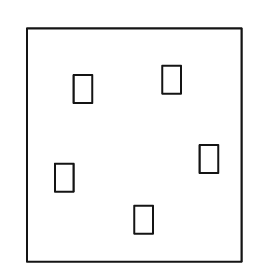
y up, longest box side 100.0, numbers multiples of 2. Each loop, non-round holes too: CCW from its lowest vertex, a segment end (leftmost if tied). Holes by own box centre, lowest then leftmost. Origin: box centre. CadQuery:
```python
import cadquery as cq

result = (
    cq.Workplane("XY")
    .moveTo(-46.0, -50.0)
    .lineTo(46.0, -50.0)
    .lineTo(46.0, 50.0)
    .lineTo(-46.0, 50.0)
    .close()
    .moveTo(0.0, -38.0)
    .lineTo(8.0, -38.0)
    .lineTo(8.0, -26.0)
    .lineTo(0.0, -26.0)
    .close()
    .moveTo(-34.0, -20.0)
    .lineTo(-26.0, -20.0)
    .lineTo(-26.0, -8.0)
    .lineTo(-34.0, -8.0)
    .close()
    .moveTo(28.0, -12.0)
    .lineTo(36.0, -12.0)
    .lineTo(36.0, 0.0)
    .lineTo(28.0, 0.0)
    .close()
    .moveTo(-26.0, 18.0)
    .lineTo(-18.0, 18.0)
    .lineTo(-18.0, 30.0)
    .lineTo(-26.0, 30.0)
    .close()
    .moveTo(12.0, 22.0)
    .lineTo(20.0, 22.0)
    .lineTo(20.0, 34.0)
    .lineTo(12.0, 34.0)
    .close()
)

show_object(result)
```